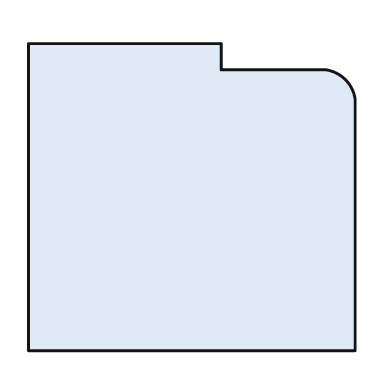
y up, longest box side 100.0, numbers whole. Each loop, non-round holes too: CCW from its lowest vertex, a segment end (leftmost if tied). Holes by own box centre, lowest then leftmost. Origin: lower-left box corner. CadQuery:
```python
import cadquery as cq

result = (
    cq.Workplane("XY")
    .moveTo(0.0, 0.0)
    .lineTo(100.0, 0.0)
    .lineTo(100.0, 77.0)
    .threePointArc((97.0, 83.0), (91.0, 86.0))
    .lineTo(59.0, 86.0)
    .lineTo(59.0, 94.0)
    .lineTo(0.0, 94.0)
    .close()
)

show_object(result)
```